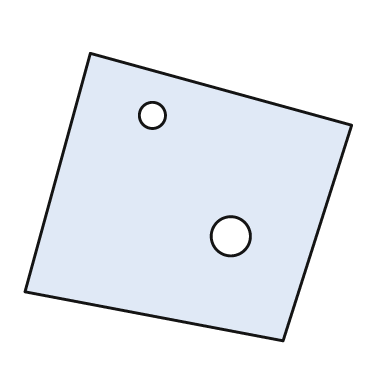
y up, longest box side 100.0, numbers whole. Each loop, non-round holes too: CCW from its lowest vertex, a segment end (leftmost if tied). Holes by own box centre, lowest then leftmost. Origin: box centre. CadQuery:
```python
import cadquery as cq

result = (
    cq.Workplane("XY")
    .moveTo(29.0, -44.0)
    .lineTo(50.0, 22.0)
    .lineTo(-30.0, 44.0)
    .lineTo(-50.0, -29.0)
    .close()
    .moveTo(13.0, -12.0)
    .circle(6.0)
    .moveTo(-11.0, 25.0)
    .circle(4.0)
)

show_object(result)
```